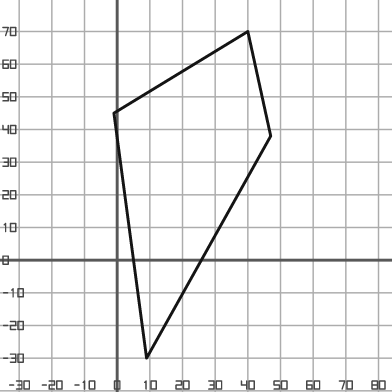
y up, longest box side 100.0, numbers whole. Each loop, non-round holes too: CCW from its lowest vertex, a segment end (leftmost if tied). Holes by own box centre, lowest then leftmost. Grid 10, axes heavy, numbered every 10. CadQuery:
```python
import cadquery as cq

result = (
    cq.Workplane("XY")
    .moveTo(9.0, -30.0)
    .lineTo(47.0, 38.0)
    .lineTo(40.0, 70.0)
    .lineTo(-1.0, 45.0)
    .close()
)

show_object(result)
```